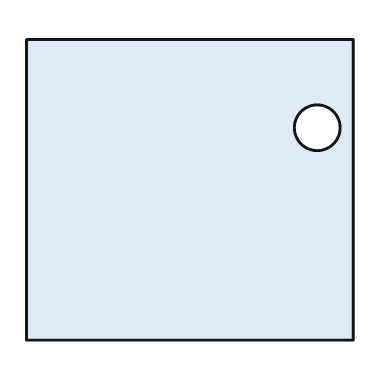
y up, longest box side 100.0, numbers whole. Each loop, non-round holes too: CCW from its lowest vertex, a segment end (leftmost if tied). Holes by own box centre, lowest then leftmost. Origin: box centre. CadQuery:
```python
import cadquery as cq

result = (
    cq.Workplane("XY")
    .moveTo(-50.0, -46.0)
    .lineTo(50.0, -46.0)
    .lineTo(50.0, 46.0)
    .lineTo(-50.0, 46.0)
    .close()
    .moveTo(39.0, 19.0)
    .circle(7.0)
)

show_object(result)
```